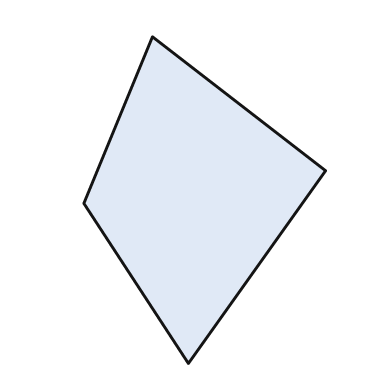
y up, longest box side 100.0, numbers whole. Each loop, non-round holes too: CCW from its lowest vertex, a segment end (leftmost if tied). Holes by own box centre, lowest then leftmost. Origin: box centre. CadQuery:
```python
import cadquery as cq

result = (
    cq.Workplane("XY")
    .moveTo(-5.0, -50.0)
    .lineTo(37.0, 9.0)
    .lineTo(-16.0, 50.0)
    .lineTo(-37.0, -1.0)
    .close()
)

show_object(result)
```